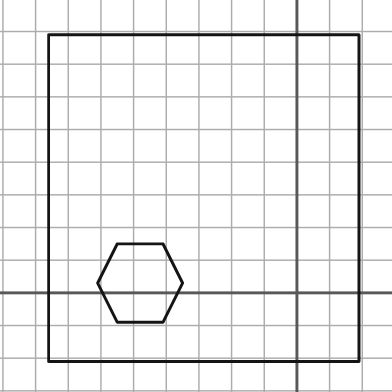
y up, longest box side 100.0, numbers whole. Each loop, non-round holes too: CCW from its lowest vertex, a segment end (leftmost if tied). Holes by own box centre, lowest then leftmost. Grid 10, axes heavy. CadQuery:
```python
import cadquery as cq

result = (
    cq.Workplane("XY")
    .moveTo(-76.0, -21.0)
    .lineTo(19.0, -21.0)
    .lineTo(19.0, 79.0)
    .lineTo(-76.0, 79.0)
    .close()
    .moveTo(-55.0, -9.0)
    .lineTo(-41.0, -9.0)
    .lineTo(-35.0, 3.0)
    .lineTo(-41.0, 15.0)
    .lineTo(-55.0, 15.0)
    .lineTo(-61.0, 3.0)
    .close()
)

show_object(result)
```